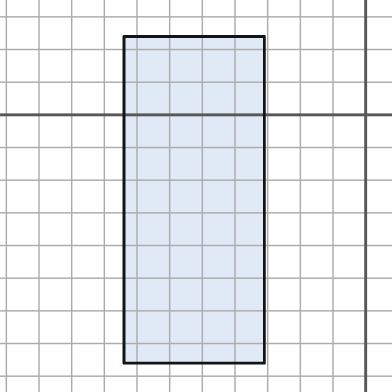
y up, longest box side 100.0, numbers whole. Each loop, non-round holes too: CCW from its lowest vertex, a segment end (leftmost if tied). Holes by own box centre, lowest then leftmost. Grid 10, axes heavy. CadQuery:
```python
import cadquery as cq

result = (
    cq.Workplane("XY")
    .moveTo(-74.0, -76.0)
    .lineTo(-31.0, -76.0)
    .lineTo(-31.0, 24.0)
    .lineTo(-74.0, 24.0)
    .close()
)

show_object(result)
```